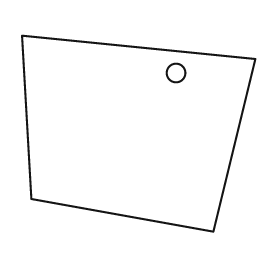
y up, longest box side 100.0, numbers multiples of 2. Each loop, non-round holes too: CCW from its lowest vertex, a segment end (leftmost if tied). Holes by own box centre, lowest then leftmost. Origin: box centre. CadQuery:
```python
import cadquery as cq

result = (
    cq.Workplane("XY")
    .moveTo(32.0, -42.0)
    .lineTo(50.0, 32.0)
    .lineTo(-50.0, 42.0)
    .lineTo(-46.0, -28.0)
    .close()
    .moveTo(16.0, 26.0)
    .circle(4.0)
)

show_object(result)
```